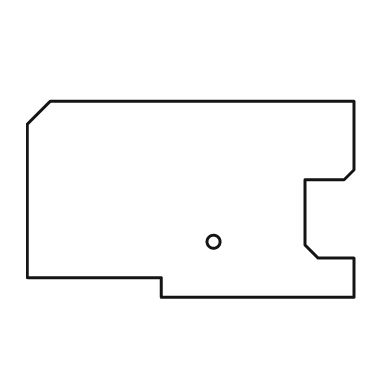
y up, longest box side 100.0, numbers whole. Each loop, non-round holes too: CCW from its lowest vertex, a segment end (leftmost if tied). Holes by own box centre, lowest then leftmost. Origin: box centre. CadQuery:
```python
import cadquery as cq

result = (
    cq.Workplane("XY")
    .moveTo(-9.0, -30.0)
    .lineTo(50.0, -30.0)
    .lineTo(50.0, -18.0)
    .lineTo(39.0, -18.0)
    .lineTo(35.0, -14.0)
    .lineTo(35.0, 6.0)
    .lineTo(47.0, 6.0)
    .lineTo(50.0, 9.0)
    .lineTo(50.0, 30.0)
    .lineTo(-43.0, 30.0)
    .lineTo(-50.0, 23.0)
    .lineTo(-50.0, -24.0)
    .lineTo(-9.0, -24.0)
    .close()
    .moveTo(7.0, -13.0)
    .circle(2.0)
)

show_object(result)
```